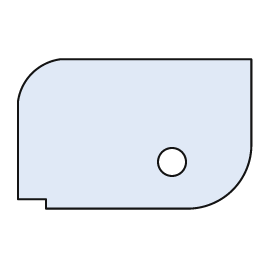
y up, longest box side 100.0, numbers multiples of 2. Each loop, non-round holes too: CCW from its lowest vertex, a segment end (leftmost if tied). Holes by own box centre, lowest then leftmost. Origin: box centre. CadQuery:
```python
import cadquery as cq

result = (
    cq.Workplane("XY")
    .moveTo(-38.0, -32.0)
    .lineTo(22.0, -32.0)
    .threePointArc((42.0, -24.0), (50.0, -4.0))
    .lineTo(50.0, 32.0)
    .lineTo(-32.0, 32.0)
    .threePointArc((-44.0, 26.0), (-50.0, 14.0))
    .lineTo(-50.0, -28.0)
    .lineTo(-38.0, -28.0)
    .close()
    .moveTo(16.0, -12.0)
    .circle(6.0)
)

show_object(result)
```